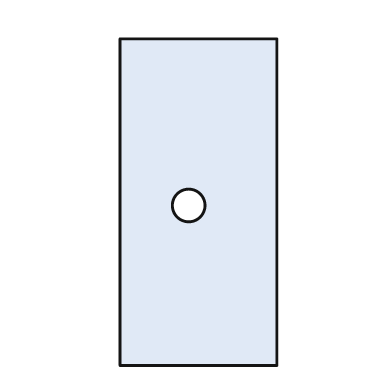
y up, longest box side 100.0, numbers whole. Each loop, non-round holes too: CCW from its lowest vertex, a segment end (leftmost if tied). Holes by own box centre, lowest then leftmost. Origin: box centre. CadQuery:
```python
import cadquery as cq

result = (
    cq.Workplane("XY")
    .moveTo(-24.0, -50.0)
    .lineTo(24.0, -50.0)
    .lineTo(24.0, 50.0)
    .lineTo(-24.0, 50.0)
    .close()
    .moveTo(-3.0, -1.0)
    .circle(5.0)
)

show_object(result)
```